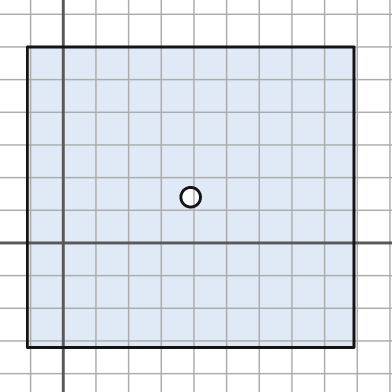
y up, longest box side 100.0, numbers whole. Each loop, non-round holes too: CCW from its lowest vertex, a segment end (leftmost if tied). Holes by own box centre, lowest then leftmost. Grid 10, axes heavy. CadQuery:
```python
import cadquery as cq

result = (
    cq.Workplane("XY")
    .moveTo(-11.0, -32.0)
    .lineTo(89.0, -32.0)
    .lineTo(89.0, 60.0)
    .lineTo(-11.0, 60.0)
    .close()
    .moveTo(39.0, 14.0)
    .circle(3.0)
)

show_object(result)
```